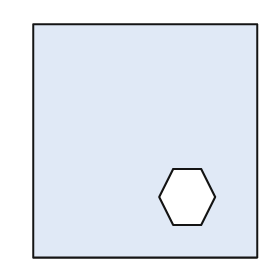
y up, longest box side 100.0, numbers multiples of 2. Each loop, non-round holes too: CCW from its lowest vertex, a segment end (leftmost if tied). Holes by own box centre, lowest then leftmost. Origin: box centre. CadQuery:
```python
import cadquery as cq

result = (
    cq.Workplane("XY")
    .moveTo(-48.0, -50.0)
    .lineTo(48.0, -50.0)
    .lineTo(48.0, 50.0)
    .lineTo(-48.0, 50.0)
    .close()
    .moveTo(12.0, -36.0)
    .lineTo(24.0, -36.0)
    .lineTo(30.0, -24.0)
    .lineTo(24.0, -12.0)
    .lineTo(12.0, -12.0)
    .lineTo(6.0, -24.0)
    .close()
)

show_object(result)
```